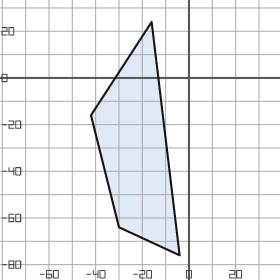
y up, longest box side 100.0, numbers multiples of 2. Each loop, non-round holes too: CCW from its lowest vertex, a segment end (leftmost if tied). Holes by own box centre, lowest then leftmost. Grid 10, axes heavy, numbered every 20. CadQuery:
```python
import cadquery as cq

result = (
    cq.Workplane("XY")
    .moveTo(-4.0, -76.0)
    .lineTo(-16.0, 24.0)
    .lineTo(-42.0, -16.0)
    .lineTo(-30.0, -64.0)
    .close()
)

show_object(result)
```